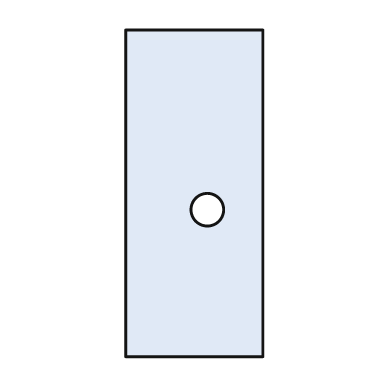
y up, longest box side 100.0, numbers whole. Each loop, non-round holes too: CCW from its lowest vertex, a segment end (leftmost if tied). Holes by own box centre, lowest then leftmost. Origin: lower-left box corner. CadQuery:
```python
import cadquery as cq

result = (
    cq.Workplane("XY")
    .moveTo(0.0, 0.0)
    .lineTo(42.0, 0.0)
    .lineTo(42.0, 100.0)
    .lineTo(0.0, 100.0)
    .close()
    .moveTo(25.0, 45.0)
    .circle(5.0)
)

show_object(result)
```